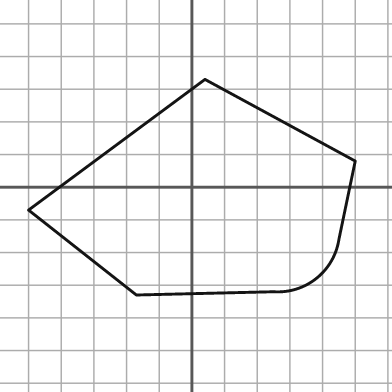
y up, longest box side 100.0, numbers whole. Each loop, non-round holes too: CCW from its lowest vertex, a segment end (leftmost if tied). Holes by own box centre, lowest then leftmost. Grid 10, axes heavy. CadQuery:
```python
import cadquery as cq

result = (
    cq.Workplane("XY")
    .moveTo(-17.0, -33.0)
    .lineTo(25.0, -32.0)
    .threePointArc((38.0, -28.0), (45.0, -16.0))
    .lineTo(50.0, 8.0)
    .lineTo(4.0, 33.0)
    .lineTo(-50.0, -7.0)
    .close()
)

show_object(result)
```